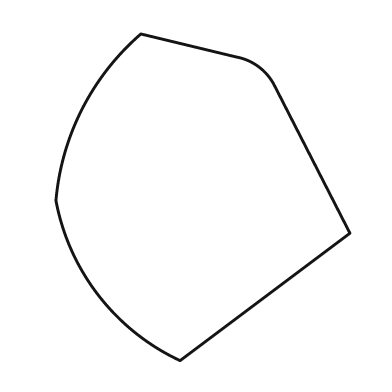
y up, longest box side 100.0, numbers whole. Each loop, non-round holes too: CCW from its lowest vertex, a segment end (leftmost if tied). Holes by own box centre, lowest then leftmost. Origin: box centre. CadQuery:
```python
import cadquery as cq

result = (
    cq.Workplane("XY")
    .moveTo(-7.0, -50.0)
    .lineTo(45.0, -11.0)
    .lineTo(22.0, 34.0)
    .threePointArc((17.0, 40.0), (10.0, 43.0))
    .lineTo(-19.0, 50.0)
    .threePointArc((-37.0, 27.0), (-45.0, -1.0))
    .threePointArc((-32.0, -30.0), (-7.0, -50.0))
    .close()
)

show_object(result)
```